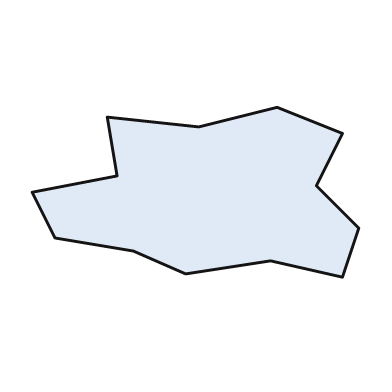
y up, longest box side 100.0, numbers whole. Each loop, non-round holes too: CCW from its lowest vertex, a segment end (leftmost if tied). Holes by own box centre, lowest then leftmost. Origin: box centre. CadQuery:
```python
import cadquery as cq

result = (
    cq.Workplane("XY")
    .moveTo(45.0, -26.0)
    .lineTo(50.0, -11.0)
    .lineTo(37.0, 2.0)
    .lineTo(45.0, 18.0)
    .lineTo(25.0, 26.0)
    .lineTo(1.0, 20.0)
    .lineTo(-27.0, 23.0)
    .lineTo(-24.0, 5.0)
    .lineTo(-50.0, 0.0)
    .lineTo(-43.0, -14.0)
    .lineTo(-19.0, -18.0)
    .lineTo(-3.0, -25.0)
    .lineTo(23.0, -21.0)
    .close()
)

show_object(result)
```